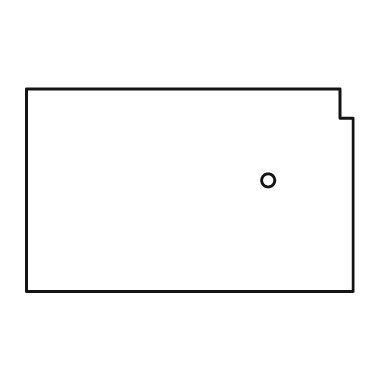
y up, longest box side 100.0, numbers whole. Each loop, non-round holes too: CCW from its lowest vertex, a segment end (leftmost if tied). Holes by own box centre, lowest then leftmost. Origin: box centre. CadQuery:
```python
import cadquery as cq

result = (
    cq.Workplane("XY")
    .moveTo(-50.0, -31.0)
    .lineTo(50.0, -31.0)
    .lineTo(50.0, 22.0)
    .lineTo(46.0, 22.0)
    .lineTo(46.0, 31.0)
    .lineTo(-50.0, 31.0)
    .close()
    .moveTo(24.0, 3.0)
    .circle(2.0)
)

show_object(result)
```